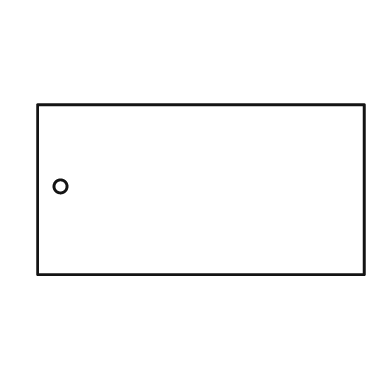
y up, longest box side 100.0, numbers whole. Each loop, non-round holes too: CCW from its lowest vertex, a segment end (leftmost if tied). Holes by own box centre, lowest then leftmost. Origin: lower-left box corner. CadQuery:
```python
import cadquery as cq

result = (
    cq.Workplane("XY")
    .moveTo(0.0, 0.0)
    .lineTo(100.0, 0.0)
    .lineTo(100.0, 52.0)
    .lineTo(0.0, 52.0)
    .close()
    .moveTo(7.0, 27.0)
    .circle(2.0)
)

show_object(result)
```